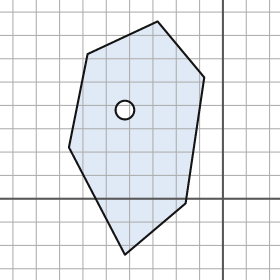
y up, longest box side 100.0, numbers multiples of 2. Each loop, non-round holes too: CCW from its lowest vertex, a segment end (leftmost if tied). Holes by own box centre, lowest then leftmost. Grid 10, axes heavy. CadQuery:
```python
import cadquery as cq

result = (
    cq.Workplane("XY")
    .moveTo(-42.0, -24.0)
    .lineTo(-16.0, -2.0)
    .lineTo(-8.0, 52.0)
    .lineTo(-28.0, 76.0)
    .lineTo(-58.0, 62.0)
    .lineTo(-66.0, 22.0)
    .close()
    .moveTo(-42.0, 38.0)
    .circle(4.0)
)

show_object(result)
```